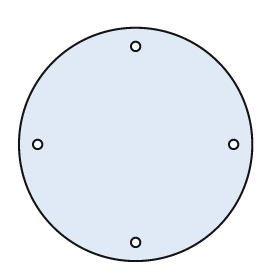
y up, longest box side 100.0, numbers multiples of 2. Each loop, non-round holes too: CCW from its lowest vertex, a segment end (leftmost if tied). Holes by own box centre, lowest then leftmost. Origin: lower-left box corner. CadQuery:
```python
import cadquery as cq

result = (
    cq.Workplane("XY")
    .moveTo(50.0, 50.0)
    .circle(50.0)
    .moveTo(50.0, 8.0)
    .circle(2.0)
    .moveTo(8.0, 50.0)
    .circle(2.0)
    .moveTo(92.0, 50.0)
    .circle(2.0)
    .moveTo(50.0, 92.0)
    .circle(2.0)
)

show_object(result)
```